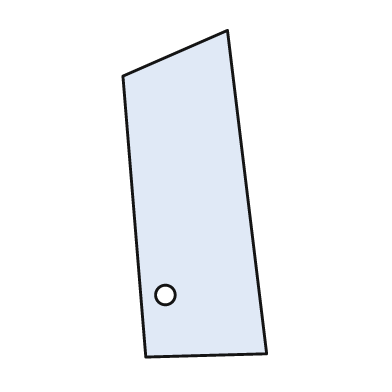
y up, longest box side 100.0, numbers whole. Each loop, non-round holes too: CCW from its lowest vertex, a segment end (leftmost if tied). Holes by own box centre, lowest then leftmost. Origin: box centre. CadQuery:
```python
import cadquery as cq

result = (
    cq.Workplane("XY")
    .moveTo(-15.0, -50.0)
    .lineTo(22.0, -49.0)
    .lineTo(10.0, 50.0)
    .lineTo(-22.0, 36.0)
    .close()
    .moveTo(-9.0, -31.0)
    .circle(3.0)
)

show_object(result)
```